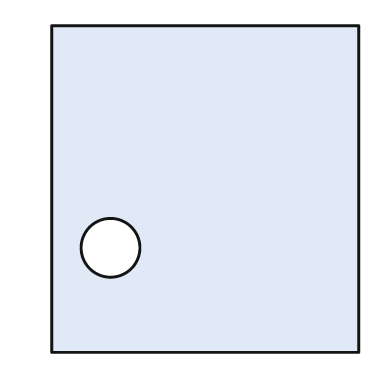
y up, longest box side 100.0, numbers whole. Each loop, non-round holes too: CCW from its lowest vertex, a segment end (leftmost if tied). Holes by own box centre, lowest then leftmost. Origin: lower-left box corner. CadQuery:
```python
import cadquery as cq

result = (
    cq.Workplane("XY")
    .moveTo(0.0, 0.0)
    .lineTo(94.0, 0.0)
    .lineTo(94.0, 100.0)
    .lineTo(0.0, 100.0)
    .close()
    .moveTo(18.0, 32.0)
    .circle(9.0)
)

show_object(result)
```